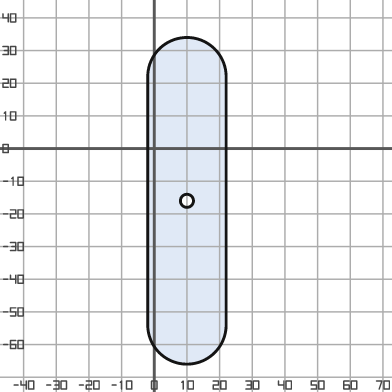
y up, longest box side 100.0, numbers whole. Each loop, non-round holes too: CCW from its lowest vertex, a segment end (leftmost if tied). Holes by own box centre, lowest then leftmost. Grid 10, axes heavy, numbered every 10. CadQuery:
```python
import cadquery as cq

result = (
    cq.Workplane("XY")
    .moveTo(-2.0, -54.0)
    .threePointArc((10.0, -66.0), (22.0, -54.0))
    .lineTo(22.0, 22.0)
    .threePointArc((10.0, 34.0), (-2.0, 22.0))
    .close()
    .moveTo(10.0, -16.0)
    .circle(2.0)
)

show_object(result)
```